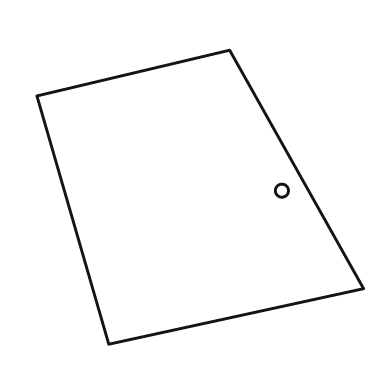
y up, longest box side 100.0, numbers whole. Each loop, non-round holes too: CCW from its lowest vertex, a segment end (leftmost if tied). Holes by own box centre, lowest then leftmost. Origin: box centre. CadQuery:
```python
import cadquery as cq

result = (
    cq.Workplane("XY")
    .moveTo(-28.0, -45.0)
    .lineTo(50.0, -28.0)
    .lineTo(9.0, 45.0)
    .lineTo(-50.0, 31.0)
    .close()
    .moveTo(25.0, 2.0)
    .circle(2.0)
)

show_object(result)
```